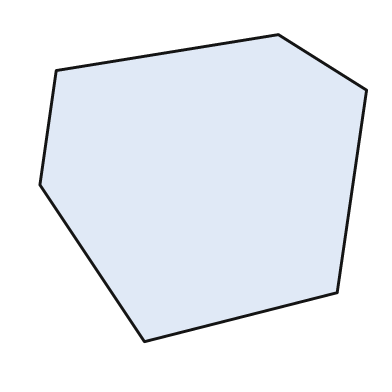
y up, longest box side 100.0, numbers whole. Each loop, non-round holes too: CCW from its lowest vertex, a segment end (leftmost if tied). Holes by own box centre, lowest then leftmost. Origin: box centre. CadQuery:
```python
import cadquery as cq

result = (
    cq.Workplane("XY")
    .moveTo(-18.0, -47.0)
    .lineTo(41.0, -32.0)
    .lineTo(50.0, 30.0)
    .lineTo(23.0, 47.0)
    .lineTo(-45.0, 36.0)
    .lineTo(-50.0, 1.0)
    .close()
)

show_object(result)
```